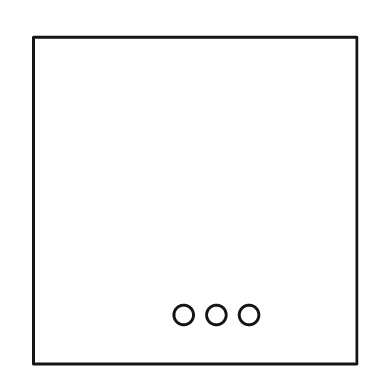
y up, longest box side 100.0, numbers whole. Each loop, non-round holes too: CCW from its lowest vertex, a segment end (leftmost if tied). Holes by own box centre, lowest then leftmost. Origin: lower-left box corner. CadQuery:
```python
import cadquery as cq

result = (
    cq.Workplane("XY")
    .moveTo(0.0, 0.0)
    .lineTo(99.0, 0.0)
    .lineTo(99.0, 100.0)
    .lineTo(0.0, 100.0)
    .close()
    .moveTo(46.0, 15.0)
    .circle(3.0)
    .moveTo(56.0, 15.0)
    .circle(3.0)
    .moveTo(66.0, 15.0)
    .circle(3.0)
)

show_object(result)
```